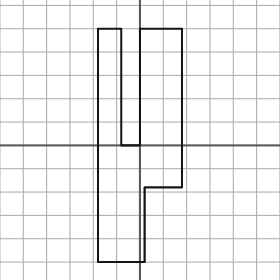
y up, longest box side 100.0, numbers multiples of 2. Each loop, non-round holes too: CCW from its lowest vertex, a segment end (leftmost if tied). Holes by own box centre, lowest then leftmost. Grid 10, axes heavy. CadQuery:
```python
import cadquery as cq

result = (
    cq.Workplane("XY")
    .moveTo(-18.0, -50.0)
    .lineTo(2.0, -50.0)
    .lineTo(2.0, -18.0)
    .lineTo(18.0, -18.0)
    .lineTo(18.0, 50.0)
    .lineTo(0.0, 50.0)
    .lineTo(0.0, 0.0)
    .lineTo(-8.0, 0.0)
    .lineTo(-8.0, 50.0)
    .lineTo(-18.0, 50.0)
    .close()
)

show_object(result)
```